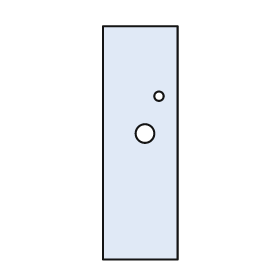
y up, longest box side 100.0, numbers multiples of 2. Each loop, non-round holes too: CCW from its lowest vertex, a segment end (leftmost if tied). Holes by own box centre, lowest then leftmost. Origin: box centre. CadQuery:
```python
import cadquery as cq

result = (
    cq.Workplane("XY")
    .moveTo(-16.0, -50.0)
    .lineTo(16.0, -50.0)
    .lineTo(16.0, 50.0)
    .lineTo(-16.0, 50.0)
    .close()
    .moveTo(2.0, 4.0)
    .circle(4.0)
    .moveTo(8.0, 20.0)
    .circle(2.0)
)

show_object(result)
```